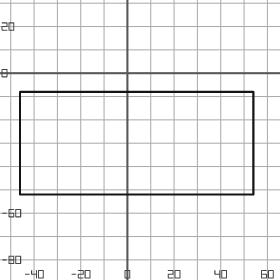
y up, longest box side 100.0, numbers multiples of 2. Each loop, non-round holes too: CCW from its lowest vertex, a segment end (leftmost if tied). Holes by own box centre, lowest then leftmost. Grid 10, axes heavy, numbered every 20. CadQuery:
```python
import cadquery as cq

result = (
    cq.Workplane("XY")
    .moveTo(-46.0, -52.0)
    .lineTo(54.0, -52.0)
    .lineTo(54.0, -8.0)
    .lineTo(-46.0, -8.0)
    .close()
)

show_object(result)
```